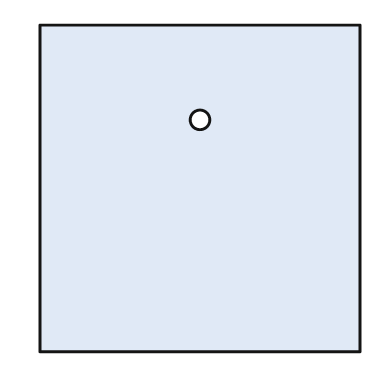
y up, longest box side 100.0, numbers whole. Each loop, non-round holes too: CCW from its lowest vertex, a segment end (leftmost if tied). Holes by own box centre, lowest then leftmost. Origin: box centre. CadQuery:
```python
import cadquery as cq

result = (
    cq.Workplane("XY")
    .moveTo(-49.0, -50.0)
    .lineTo(49.0, -50.0)
    .lineTo(49.0, 50.0)
    .lineTo(-49.0, 50.0)
    .close()
    .moveTo(0.0, 21.0)
    .circle(3.0)
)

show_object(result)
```